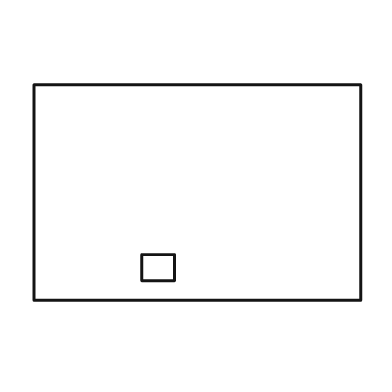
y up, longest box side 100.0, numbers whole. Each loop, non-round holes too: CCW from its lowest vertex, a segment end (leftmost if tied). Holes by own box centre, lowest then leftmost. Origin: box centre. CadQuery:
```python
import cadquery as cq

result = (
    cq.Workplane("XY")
    .moveTo(-50.0, -33.0)
    .lineTo(50.0, -33.0)
    .lineTo(50.0, 33.0)
    .lineTo(-50.0, 33.0)
    .close()
    .moveTo(-17.0, -27.0)
    .lineTo(-7.0, -27.0)
    .lineTo(-7.0, -19.0)
    .lineTo(-17.0, -19.0)
    .close()
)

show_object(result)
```